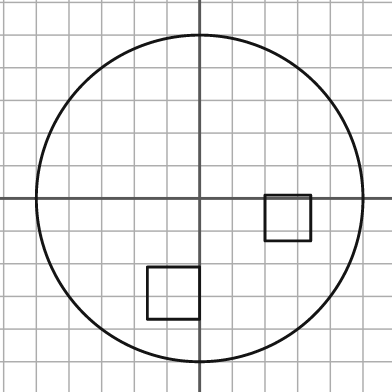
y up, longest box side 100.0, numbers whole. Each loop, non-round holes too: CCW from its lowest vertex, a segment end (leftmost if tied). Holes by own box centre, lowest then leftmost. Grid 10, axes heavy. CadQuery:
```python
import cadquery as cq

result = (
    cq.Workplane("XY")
    .moveTo(0.0, 0.0)
    .circle(50.0)
    .moveTo(-16.0, -37.0)
    .lineTo(0.0, -37.0)
    .lineTo(0.0, -21.0)
    .lineTo(-16.0, -21.0)
    .close()
    .moveTo(20.0, -13.0)
    .lineTo(34.0, -13.0)
    .lineTo(34.0, 1.0)
    .lineTo(20.0, 1.0)
    .close()
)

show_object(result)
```